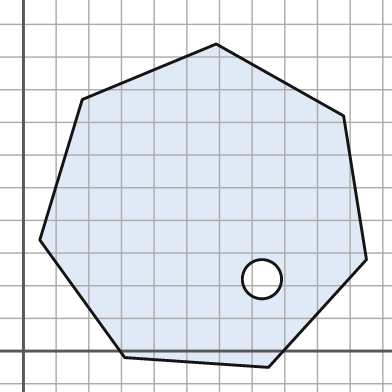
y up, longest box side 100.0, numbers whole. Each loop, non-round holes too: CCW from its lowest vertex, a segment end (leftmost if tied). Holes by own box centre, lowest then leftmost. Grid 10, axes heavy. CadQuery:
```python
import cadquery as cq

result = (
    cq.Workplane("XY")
    .moveTo(75.0, -5.0)
    .lineTo(105.0, 28.0)
    .lineTo(98.0, 72.0)
    .lineTo(59.0, 94.0)
    .lineTo(18.0, 77.0)
    .lineTo(5.0, 34.0)
    .lineTo(31.0, -2.0)
    .close()
    .moveTo(73.0, 22.0)
    .circle(6.0)
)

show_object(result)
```